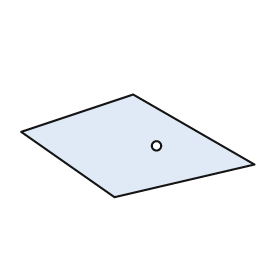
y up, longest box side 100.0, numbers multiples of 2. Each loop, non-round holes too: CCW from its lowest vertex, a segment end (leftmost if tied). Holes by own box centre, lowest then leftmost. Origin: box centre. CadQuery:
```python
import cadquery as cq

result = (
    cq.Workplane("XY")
    .moveTo(-10.0, -22.0)
    .lineTo(50.0, -8.0)
    .lineTo(-2.0, 22.0)
    .lineTo(-50.0, 6.0)
    .close()
    .moveTo(8.0, 0.0)
    .circle(2.0)
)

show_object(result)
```